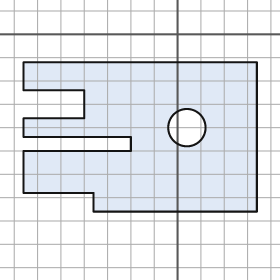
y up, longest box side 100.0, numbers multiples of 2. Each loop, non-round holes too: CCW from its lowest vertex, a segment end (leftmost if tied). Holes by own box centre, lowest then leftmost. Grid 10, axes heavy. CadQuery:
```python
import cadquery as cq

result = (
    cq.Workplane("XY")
    .moveTo(-36.0, -76.0)
    .lineTo(34.0, -76.0)
    .lineTo(34.0, -12.0)
    .lineTo(-66.0, -12.0)
    .lineTo(-66.0, -24.0)
    .lineTo(-40.0, -24.0)
    .lineTo(-40.0, -36.0)
    .lineTo(-66.0, -36.0)
    .lineTo(-66.0, -44.0)
    .lineTo(-20.0, -44.0)
    .lineTo(-20.0, -50.0)
    .lineTo(-66.0, -50.0)
    .lineTo(-66.0, -68.0)
    .lineTo(-36.0, -68.0)
    .close()
    .moveTo(4.0, -40.0)
    .circle(8.0)
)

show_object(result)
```